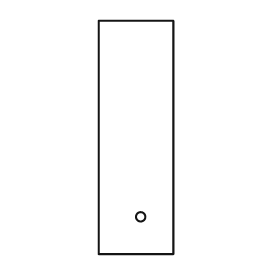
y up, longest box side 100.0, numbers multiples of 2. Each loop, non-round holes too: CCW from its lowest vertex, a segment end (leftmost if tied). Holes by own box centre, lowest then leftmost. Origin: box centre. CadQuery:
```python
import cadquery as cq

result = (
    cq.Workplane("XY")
    .moveTo(-16.0, -50.0)
    .lineTo(16.0, -50.0)
    .lineTo(16.0, 50.0)
    .lineTo(-16.0, 50.0)
    .close()
    .moveTo(2.0, -34.0)
    .circle(2.0)
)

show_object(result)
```